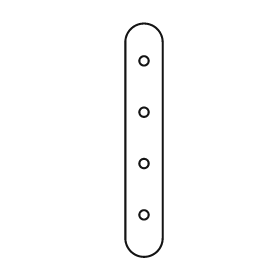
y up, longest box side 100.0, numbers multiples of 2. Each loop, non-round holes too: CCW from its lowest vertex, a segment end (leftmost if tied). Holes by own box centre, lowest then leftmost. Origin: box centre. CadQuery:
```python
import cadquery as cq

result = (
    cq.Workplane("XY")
    .moveTo(-8.0, -42.0)
    .threePointArc((0.0, -50.0), (8.0, -42.0))
    .lineTo(8.0, 42.0)
    .threePointArc((0.0, 50.0), (-8.0, 42.0))
    .close()
    .moveTo(0.0, -32.0)
    .circle(2.0)
    .moveTo(0.0, -10.0)
    .circle(2.0)
    .moveTo(0.0, 12.0)
    .circle(2.0)
    .moveTo(0.0, 34.0)
    .circle(2.0)
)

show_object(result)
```